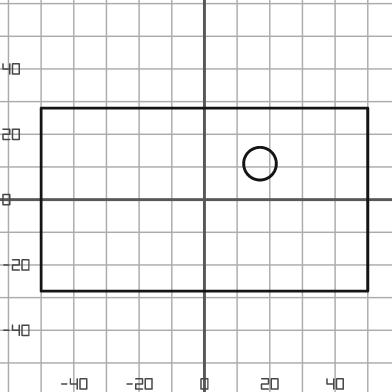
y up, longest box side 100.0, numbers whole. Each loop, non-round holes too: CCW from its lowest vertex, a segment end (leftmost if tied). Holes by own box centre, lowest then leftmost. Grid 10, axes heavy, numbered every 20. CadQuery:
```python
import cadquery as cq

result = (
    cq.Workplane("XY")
    .moveTo(-50.0, -28.0)
    .lineTo(50.0, -28.0)
    .lineTo(50.0, 28.0)
    .lineTo(-50.0, 28.0)
    .close()
    .moveTo(17.0, 11.0)
    .circle(5.0)
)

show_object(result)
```